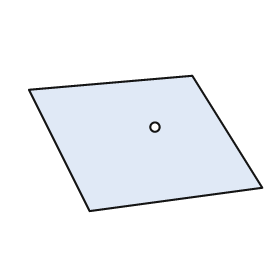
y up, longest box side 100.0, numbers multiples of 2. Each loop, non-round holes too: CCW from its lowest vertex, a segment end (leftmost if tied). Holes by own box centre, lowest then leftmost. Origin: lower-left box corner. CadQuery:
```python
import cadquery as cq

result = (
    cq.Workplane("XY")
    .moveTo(26.0, 0.0)
    .lineTo(100.0, 10.0)
    .lineTo(70.0, 58.0)
    .lineTo(0.0, 52.0)
    .close()
    .moveTo(54.0, 36.0)
    .circle(2.0)
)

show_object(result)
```